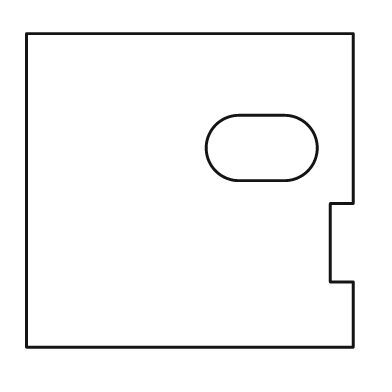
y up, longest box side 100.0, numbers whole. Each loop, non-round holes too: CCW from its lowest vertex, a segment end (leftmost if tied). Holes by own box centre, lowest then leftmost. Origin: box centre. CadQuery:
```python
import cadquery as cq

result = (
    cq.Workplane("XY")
    .moveTo(-50.0, -48.0)
    .lineTo(50.0, -48.0)
    .lineTo(50.0, -28.0)
    .lineTo(43.0, -28.0)
    .lineTo(43.0, -4.0)
    .lineTo(50.0, -4.0)
    .lineTo(50.0, 48.0)
    .lineTo(-50.0, 48.0)
    .close()
    .moveTo(15.0, 3.0)
    .lineTo(29.0, 3.0)
    .threePointArc((39.0, 13.0), (29.0, 23.0))
    .lineTo(15.0, 23.0)
    .threePointArc((5.0, 13.0), (15.0, 3.0))
    .close()
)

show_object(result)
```